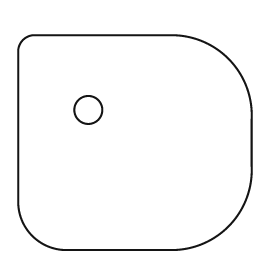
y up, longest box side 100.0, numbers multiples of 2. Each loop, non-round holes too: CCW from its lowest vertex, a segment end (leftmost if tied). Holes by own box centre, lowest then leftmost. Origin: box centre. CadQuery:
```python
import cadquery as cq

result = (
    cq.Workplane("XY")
    .moveTo(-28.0, -46.0)
    .lineTo(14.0, -46.0)
    .threePointArc((40.0, -36.0), (50.0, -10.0))
    .lineTo(50.0, 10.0)
    .threePointArc((40.0, 36.0), (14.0, 46.0))
    .lineTo(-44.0, 46.0)
    .threePointArc((-48.0, 44.0), (-50.0, 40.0))
    .lineTo(-50.0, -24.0)
    .threePointArc((-44.0, -40.0), (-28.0, -46.0))
    .close()
    .moveTo(-20.0, 14.0)
    .circle(6.0)
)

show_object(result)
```